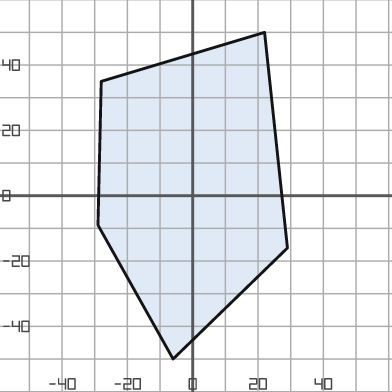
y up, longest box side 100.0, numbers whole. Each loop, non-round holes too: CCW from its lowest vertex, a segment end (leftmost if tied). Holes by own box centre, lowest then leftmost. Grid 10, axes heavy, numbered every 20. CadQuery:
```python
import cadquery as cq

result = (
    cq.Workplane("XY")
    .moveTo(-6.0, -50.0)
    .lineTo(29.0, -16.0)
    .lineTo(22.0, 50.0)
    .lineTo(-28.0, 35.0)
    .lineTo(-29.0, -9.0)
    .close()
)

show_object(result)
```